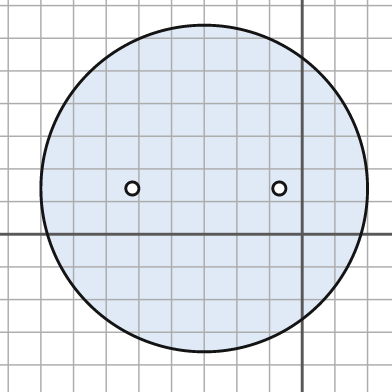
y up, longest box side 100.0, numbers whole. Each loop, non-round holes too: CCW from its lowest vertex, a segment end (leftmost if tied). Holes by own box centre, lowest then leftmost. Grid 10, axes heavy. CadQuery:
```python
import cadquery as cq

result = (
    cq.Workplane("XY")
    .moveTo(-30.0, 14.0)
    .circle(50.0)
    .moveTo(-52.0, 14.0)
    .circle(2.0)
    .moveTo(-7.0, 14.0)
    .circle(2.0)
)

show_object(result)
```